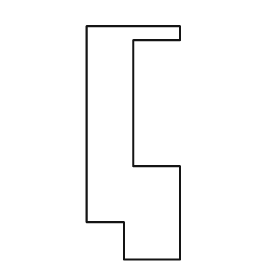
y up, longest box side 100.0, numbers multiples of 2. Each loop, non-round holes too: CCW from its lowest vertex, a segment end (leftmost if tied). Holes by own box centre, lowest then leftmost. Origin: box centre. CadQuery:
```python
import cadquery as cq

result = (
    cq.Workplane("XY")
    .moveTo(-4.0, -50.0)
    .lineTo(20.0, -50.0)
    .lineTo(20.0, -10.0)
    .lineTo(0.0, -10.0)
    .lineTo(0.0, 44.0)
    .lineTo(20.0, 44.0)
    .lineTo(20.0, 50.0)
    .lineTo(-20.0, 50.0)
    .lineTo(-20.0, -34.0)
    .lineTo(-4.0, -34.0)
    .close()
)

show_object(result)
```